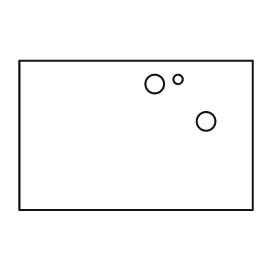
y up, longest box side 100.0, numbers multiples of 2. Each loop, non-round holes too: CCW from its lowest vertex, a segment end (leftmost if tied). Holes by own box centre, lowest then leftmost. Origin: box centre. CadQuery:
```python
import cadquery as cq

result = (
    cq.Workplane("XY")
    .moveTo(-50.0, -32.0)
    .lineTo(50.0, -32.0)
    .lineTo(50.0, 32.0)
    .lineTo(-50.0, 32.0)
    .close()
    .moveTo(30.0, 6.0)
    .circle(4.0)
    .moveTo(8.0, 22.0)
    .circle(4.0)
    .moveTo(18.0, 24.0)
    .circle(2.0)
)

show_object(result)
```